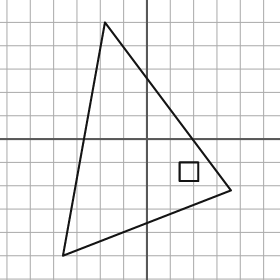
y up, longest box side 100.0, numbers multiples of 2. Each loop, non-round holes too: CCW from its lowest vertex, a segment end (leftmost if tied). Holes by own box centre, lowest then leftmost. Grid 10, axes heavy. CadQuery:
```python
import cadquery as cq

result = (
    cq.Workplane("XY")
    .moveTo(-36.0, -50.0)
    .lineTo(36.0, -22.0)
    .lineTo(-18.0, 50.0)
    .close()
    .moveTo(14.0, -18.0)
    .lineTo(22.0, -18.0)
    .lineTo(22.0, -10.0)
    .lineTo(14.0, -10.0)
    .close()
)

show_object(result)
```